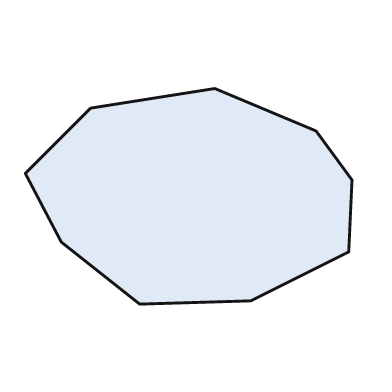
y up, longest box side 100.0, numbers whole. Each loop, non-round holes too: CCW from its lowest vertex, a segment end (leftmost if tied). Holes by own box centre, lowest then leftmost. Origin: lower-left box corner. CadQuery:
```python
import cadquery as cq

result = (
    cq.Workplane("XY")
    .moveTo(35.0, 0.0)
    .lineTo(69.0, 1.0)
    .lineTo(99.0, 16.0)
    .lineTo(100.0, 38.0)
    .lineTo(89.0, 53.0)
    .lineTo(58.0, 66.0)
    .lineTo(20.0, 60.0)
    .lineTo(0.0, 40.0)
    .lineTo(11.0, 19.0)
    .close()
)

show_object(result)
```